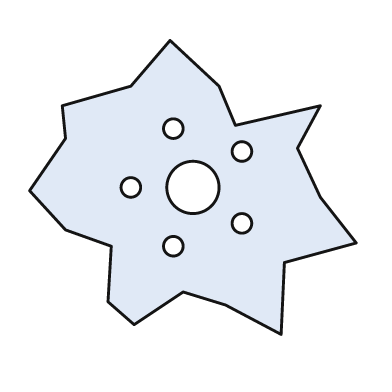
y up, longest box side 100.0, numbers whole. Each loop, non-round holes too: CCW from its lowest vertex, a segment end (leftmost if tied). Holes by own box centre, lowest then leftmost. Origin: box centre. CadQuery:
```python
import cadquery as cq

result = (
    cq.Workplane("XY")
    .moveTo(27.0, -45.0)
    .lineTo(28.0, -23.0)
    .lineTo(50.0, -17.0)
    .lineTo(39.0, -3.0)
    .lineTo(32.0, 12.0)
    .lineTo(39.0, 25.0)
    .lineTo(13.0, 19.0)
    .lineTo(8.0, 31.0)
    .lineTo(-7.0, 45.0)
    .lineTo(-19.0, 31.0)
    .lineTo(-40.0, 25.0)
    .lineTo(-39.0, 15.0)
    .lineTo(-50.0, -1.0)
    .lineTo(-39.0, -13.0)
    .lineTo(-25.0, -18.0)
    .lineTo(-26.0, -35.0)
    .lineTo(-18.0, -42.0)
    .lineTo(-3.0, -32.0)
    .lineTo(10.0, -36.0)
    .close()
    .moveTo(-6.0, -18.0)
    .circle(3.0)
    .moveTo(15.0, -11.0)
    .circle(3.0)
    .moveTo(-19.0, 0.0)
    .circle(3.0)
    .moveTo(0.0, 0.0)
    .circle(8.0)
    .moveTo(15.0, 11.0)
    .circle(3.0)
    .moveTo(-6.0, 18.0)
    .circle(3.0)
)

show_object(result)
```